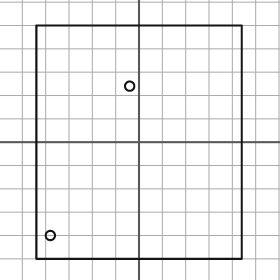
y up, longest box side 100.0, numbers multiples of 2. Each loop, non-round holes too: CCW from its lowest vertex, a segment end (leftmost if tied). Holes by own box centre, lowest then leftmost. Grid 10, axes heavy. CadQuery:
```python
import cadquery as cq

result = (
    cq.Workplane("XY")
    .moveTo(-44.0, -50.0)
    .lineTo(44.0, -50.0)
    .lineTo(44.0, 50.0)
    .lineTo(-44.0, 50.0)
    .close()
    .moveTo(-38.0, -40.0)
    .circle(2.0)
    .moveTo(-4.0, 24.0)
    .circle(2.0)
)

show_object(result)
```